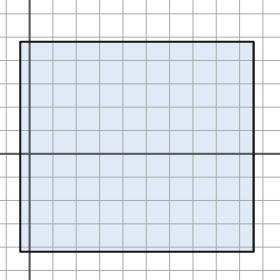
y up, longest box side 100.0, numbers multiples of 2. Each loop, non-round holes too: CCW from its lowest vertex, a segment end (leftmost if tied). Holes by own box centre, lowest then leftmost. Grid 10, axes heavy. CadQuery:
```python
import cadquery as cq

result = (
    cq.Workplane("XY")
    .moveTo(-4.0, -42.0)
    .lineTo(96.0, -42.0)
    .lineTo(96.0, 48.0)
    .lineTo(-4.0, 48.0)
    .close()
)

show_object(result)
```